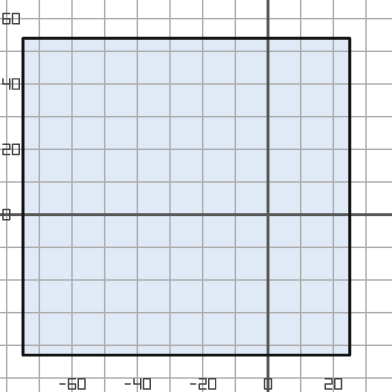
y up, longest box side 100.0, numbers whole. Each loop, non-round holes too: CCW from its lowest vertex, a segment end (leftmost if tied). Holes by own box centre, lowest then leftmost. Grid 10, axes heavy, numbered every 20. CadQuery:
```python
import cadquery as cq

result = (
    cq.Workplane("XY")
    .moveTo(-75.0, -43.0)
    .lineTo(25.0, -43.0)
    .lineTo(25.0, 54.0)
    .lineTo(-75.0, 54.0)
    .close()
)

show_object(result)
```